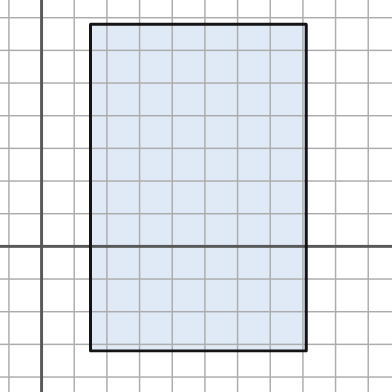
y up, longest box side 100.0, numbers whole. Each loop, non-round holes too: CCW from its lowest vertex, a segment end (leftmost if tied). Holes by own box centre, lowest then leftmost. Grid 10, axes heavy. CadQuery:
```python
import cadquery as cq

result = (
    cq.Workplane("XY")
    .moveTo(15.0, -32.0)
    .lineTo(81.0, -32.0)
    .lineTo(81.0, 68.0)
    .lineTo(15.0, 68.0)
    .close()
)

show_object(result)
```